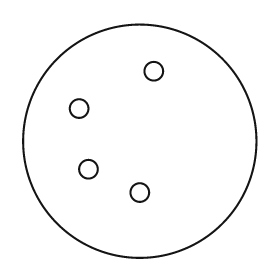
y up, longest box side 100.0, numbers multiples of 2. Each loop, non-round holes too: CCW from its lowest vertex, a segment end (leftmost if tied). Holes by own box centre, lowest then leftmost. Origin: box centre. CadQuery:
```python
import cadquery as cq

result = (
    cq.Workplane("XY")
    .moveTo(0.0, 0.0)
    .circle(50.0)
    .moveTo(0.0, -22.0)
    .circle(4.0)
    .moveTo(-22.0, -12.0)
    .circle(4.0)
    .moveTo(-26.0, 14.0)
    .circle(4.0)
    .moveTo(6.0, 30.0)
    .circle(4.0)
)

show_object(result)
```